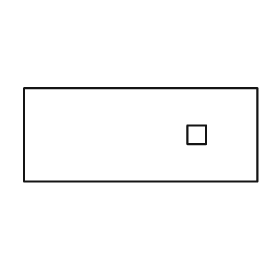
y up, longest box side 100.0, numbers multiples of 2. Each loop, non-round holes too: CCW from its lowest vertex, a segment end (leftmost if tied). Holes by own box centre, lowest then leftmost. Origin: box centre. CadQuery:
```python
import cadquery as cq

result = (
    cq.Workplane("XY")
    .moveTo(-50.0, -20.0)
    .lineTo(50.0, -20.0)
    .lineTo(50.0, 20.0)
    .lineTo(-50.0, 20.0)
    .close()
    .moveTo(20.0, -4.0)
    .lineTo(28.0, -4.0)
    .lineTo(28.0, 4.0)
    .lineTo(20.0, 4.0)
    .close()
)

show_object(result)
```